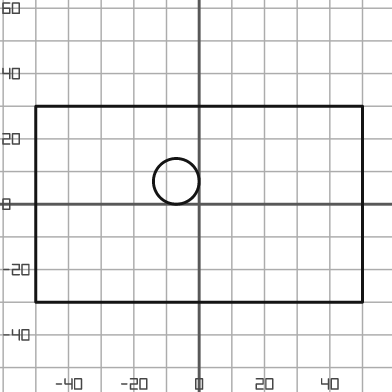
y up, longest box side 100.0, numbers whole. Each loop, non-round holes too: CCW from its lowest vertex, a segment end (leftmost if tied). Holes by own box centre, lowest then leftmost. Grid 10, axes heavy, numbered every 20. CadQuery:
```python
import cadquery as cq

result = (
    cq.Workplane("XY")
    .moveTo(-50.0, -30.0)
    .lineTo(50.0, -30.0)
    .lineTo(50.0, 30.0)
    .lineTo(-50.0, 30.0)
    .close()
    .moveTo(-7.0, 7.0)
    .circle(7.0)
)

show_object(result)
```